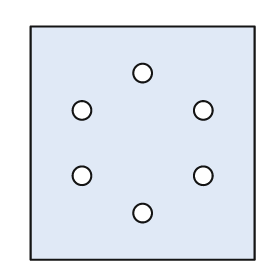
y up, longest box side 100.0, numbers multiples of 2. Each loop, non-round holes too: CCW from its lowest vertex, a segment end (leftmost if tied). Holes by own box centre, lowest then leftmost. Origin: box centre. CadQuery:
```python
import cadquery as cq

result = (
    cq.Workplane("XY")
    .moveTo(-48.0, -50.0)
    .lineTo(48.0, -50.0)
    .lineTo(48.0, 50.0)
    .lineTo(-48.0, 50.0)
    .close()
    .moveTo(0.0, -30.0)
    .circle(4.0)
    .moveTo(-26.0, -14.0)
    .circle(4.0)
    .moveTo(26.0, -14.0)
    .circle(4.0)
    .moveTo(-26.0, 14.0)
    .circle(4.0)
    .moveTo(26.0, 14.0)
    .circle(4.0)
    .moveTo(0.0, 30.0)
    .circle(4.0)
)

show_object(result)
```